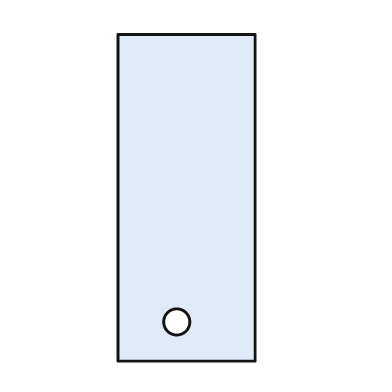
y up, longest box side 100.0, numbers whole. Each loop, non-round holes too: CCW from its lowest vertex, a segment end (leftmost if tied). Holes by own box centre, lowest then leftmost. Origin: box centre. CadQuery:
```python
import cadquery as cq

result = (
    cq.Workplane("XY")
    .moveTo(-21.0, -50.0)
    .lineTo(21.0, -50.0)
    .lineTo(21.0, 50.0)
    .lineTo(-21.0, 50.0)
    .close()
    .moveTo(-3.0, -38.0)
    .circle(4.0)
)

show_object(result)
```